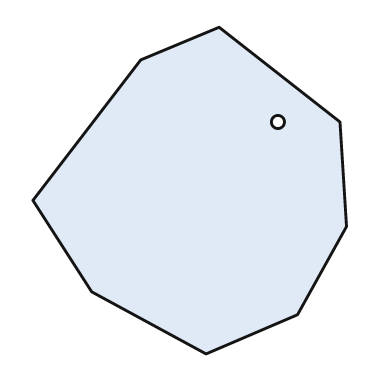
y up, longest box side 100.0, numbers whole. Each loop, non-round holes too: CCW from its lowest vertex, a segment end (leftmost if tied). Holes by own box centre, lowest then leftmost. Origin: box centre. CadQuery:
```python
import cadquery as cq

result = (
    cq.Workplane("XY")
    .moveTo(5.0, -50.0)
    .lineTo(33.0, -38.0)
    .lineTo(48.0, -11.0)
    .lineTo(46.0, 21.0)
    .lineTo(9.0, 50.0)
    .lineTo(-15.0, 40.0)
    .lineTo(-48.0, -3.0)
    .lineTo(-30.0, -31.0)
    .close()
    .moveTo(27.0, 21.0)
    .circle(2.0)
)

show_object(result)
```